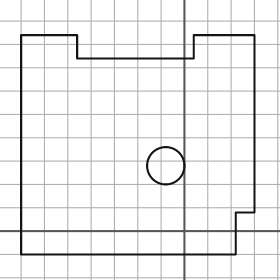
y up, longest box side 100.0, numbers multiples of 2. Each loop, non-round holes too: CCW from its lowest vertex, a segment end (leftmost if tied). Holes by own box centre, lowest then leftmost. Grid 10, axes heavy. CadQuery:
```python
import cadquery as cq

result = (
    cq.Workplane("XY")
    .moveTo(-70.0, -10.0)
    .lineTo(22.0, -10.0)
    .lineTo(22.0, 8.0)
    .lineTo(30.0, 8.0)
    .lineTo(30.0, 84.0)
    .lineTo(4.0, 84.0)
    .lineTo(4.0, 74.0)
    .lineTo(-46.0, 74.0)
    .lineTo(-46.0, 84.0)
    .lineTo(-70.0, 84.0)
    .close()
    .moveTo(-8.0, 28.0)
    .circle(8.0)
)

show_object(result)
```